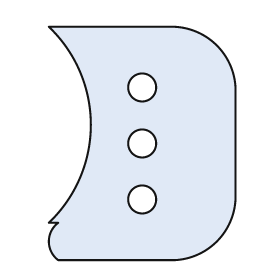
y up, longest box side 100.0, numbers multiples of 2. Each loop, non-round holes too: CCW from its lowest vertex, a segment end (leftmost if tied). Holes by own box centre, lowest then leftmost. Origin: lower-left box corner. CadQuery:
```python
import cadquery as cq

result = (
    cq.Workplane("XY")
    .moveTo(4.0, 0.0)
    .lineTo(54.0, 0.0)
    .threePointArc((72.0, 8.0), (80.0, 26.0))
    .lineTo(80.0, 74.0)
    .threePointArc((72.0, 92.0), (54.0, 100.0))
    .lineTo(0.0, 100.0)
    .threePointArc((18.0, 58.0), (0.0, 16.0))
    .lineTo(4.0, 16.0)
    .threePointArc((0.0, 8.0), (4.0, 0.0))
    .close()
    .moveTo(40.0, 26.0)
    .circle(6.0)
    .moveTo(40.0, 50.0)
    .circle(6.0)
    .moveTo(40.0, 74.0)
    .circle(6.0)
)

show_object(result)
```